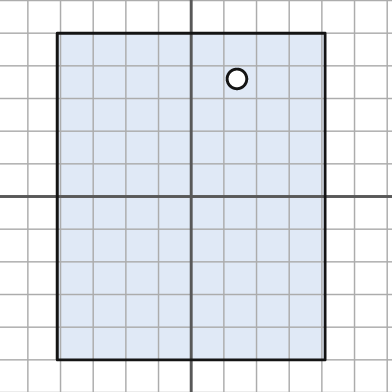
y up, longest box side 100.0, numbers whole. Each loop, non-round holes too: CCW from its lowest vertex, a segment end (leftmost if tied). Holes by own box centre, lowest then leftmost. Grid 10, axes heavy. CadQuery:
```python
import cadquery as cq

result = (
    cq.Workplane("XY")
    .moveTo(-41.0, -50.0)
    .lineTo(41.0, -50.0)
    .lineTo(41.0, 50.0)
    .lineTo(-41.0, 50.0)
    .close()
    .moveTo(14.0, 36.0)
    .circle(3.0)
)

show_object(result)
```